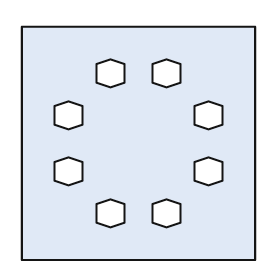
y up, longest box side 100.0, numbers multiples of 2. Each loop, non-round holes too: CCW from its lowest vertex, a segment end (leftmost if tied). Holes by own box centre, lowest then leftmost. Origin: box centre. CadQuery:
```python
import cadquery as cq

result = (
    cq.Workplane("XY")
    .moveTo(-50.0, -50.0)
    .lineTo(50.0, -50.0)
    .lineTo(50.0, 50.0)
    .lineTo(-50.0, 50.0)
    .close()
    .moveTo(-12.0, -36.0)
    .lineTo(-6.0, -34.0)
    .lineTo(-6.0, -26.0)
    .lineTo(-12.0, -24.0)
    .lineTo(-18.0, -26.0)
    .lineTo(-18.0, -34.0)
    .close()
    .moveTo(12.0, -36.0)
    .lineTo(18.0, -34.0)
    .lineTo(18.0, -26.0)
    .lineTo(12.0, -24.0)
    .lineTo(6.0, -26.0)
    .lineTo(6.0, -34.0)
    .close()
    .moveTo(-30.0, -18.0)
    .lineTo(-24.0, -16.0)
    .lineTo(-24.0, -8.0)
    .lineTo(-30.0, -6.0)
    .lineTo(-36.0, -8.0)
    .lineTo(-36.0, -16.0)
    .close()
    .moveTo(30.0, -18.0)
    .lineTo(36.0, -16.0)
    .lineTo(36.0, -8.0)
    .lineTo(30.0, -6.0)
    .lineTo(24.0, -8.0)
    .lineTo(24.0, -16.0)
    .close()
    .moveTo(-30.0, 6.0)
    .lineTo(-24.0, 8.0)
    .lineTo(-24.0, 16.0)
    .lineTo(-30.0, 18.0)
    .lineTo(-36.0, 16.0)
    .lineTo(-36.0, 8.0)
    .close()
    .moveTo(30.0, 6.0)
    .lineTo(36.0, 8.0)
    .lineTo(36.0, 16.0)
    .lineTo(30.0, 18.0)
    .lineTo(24.0, 16.0)
    .lineTo(24.0, 8.0)
    .close()
    .moveTo(-12.0, 24.0)
    .lineTo(-6.0, 26.0)
    .lineTo(-6.0, 34.0)
    .lineTo(-12.0, 36.0)
    .lineTo(-18.0, 34.0)
    .lineTo(-18.0, 26.0)
    .close()
    .moveTo(12.0, 24.0)
    .lineTo(18.0, 26.0)
    .lineTo(18.0, 34.0)
    .lineTo(12.0, 36.0)
    .lineTo(6.0, 34.0)
    .lineTo(6.0, 26.0)
    .close()
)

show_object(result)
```